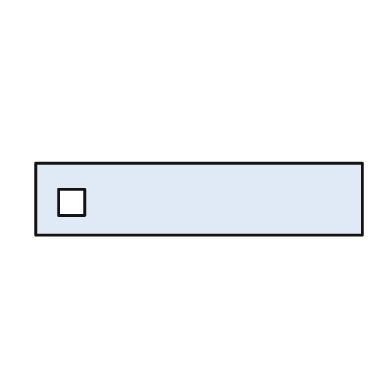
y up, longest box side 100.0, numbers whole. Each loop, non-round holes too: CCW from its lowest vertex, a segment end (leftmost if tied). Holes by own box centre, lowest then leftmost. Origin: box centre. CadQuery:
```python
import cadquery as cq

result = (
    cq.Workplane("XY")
    .moveTo(-50.0, -11.0)
    .lineTo(50.0, -11.0)
    .lineTo(50.0, 11.0)
    .lineTo(-50.0, 11.0)
    .close()
    .moveTo(-43.0, -5.0)
    .lineTo(-35.0, -5.0)
    .lineTo(-35.0, 3.0)
    .lineTo(-43.0, 3.0)
    .close()
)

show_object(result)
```